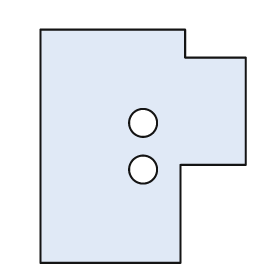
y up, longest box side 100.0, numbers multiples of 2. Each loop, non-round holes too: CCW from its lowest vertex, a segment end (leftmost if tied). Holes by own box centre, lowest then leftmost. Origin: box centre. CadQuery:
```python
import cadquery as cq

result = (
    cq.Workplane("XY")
    .moveTo(-44.0, -50.0)
    .lineTo(16.0, -50.0)
    .lineTo(16.0, -8.0)
    .lineTo(44.0, -8.0)
    .lineTo(44.0, 38.0)
    .lineTo(18.0, 38.0)
    .lineTo(18.0, 50.0)
    .lineTo(-44.0, 50.0)
    .close()
    .moveTo(0.0, -10.0)
    .circle(6.0)
    .moveTo(0.0, 10.0)
    .circle(6.0)
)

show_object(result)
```